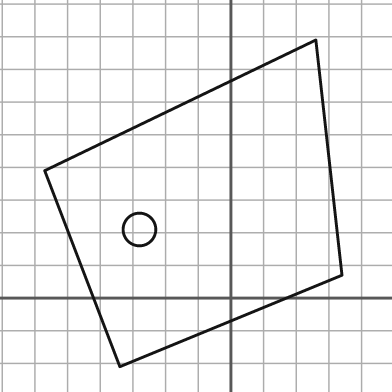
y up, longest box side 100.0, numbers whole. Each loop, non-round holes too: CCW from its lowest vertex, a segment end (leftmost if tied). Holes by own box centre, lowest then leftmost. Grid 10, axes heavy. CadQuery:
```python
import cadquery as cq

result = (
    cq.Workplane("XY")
    .moveTo(-34.0, -21.0)
    .lineTo(34.0, 7.0)
    .lineTo(26.0, 79.0)
    .lineTo(-57.0, 39.0)
    .close()
    .moveTo(-28.0, 21.0)
    .circle(5.0)
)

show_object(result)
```